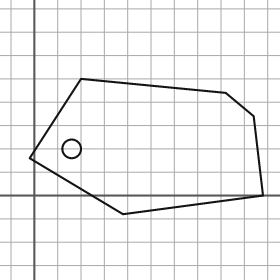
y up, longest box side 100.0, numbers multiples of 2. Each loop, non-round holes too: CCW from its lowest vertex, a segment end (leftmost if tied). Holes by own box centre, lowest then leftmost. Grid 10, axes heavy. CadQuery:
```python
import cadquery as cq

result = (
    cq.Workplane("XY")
    .moveTo(38.0, -8.0)
    .lineTo(98.0, 0.0)
    .lineTo(94.0, 34.0)
    .lineTo(82.0, 44.0)
    .lineTo(20.0, 50.0)
    .lineTo(-2.0, 16.0)
    .close()
    .moveTo(16.0, 20.0)
    .circle(4.0)
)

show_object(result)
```